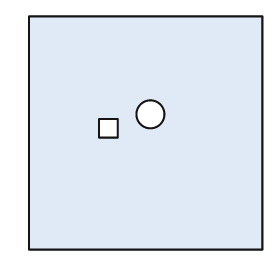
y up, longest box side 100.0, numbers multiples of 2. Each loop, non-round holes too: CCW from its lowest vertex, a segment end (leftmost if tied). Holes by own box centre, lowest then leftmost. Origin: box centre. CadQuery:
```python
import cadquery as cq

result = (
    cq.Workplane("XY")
    .moveTo(-50.0, -50.0)
    .lineTo(50.0, -50.0)
    .lineTo(50.0, 50.0)
    .lineTo(-50.0, 50.0)
    .close()
    .moveTo(-20.0, -2.0)
    .lineTo(-12.0, -2.0)
    .lineTo(-12.0, 6.0)
    .lineTo(-20.0, 6.0)
    .close()
    .moveTo(2.0, 8.0)
    .circle(6.0)
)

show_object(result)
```